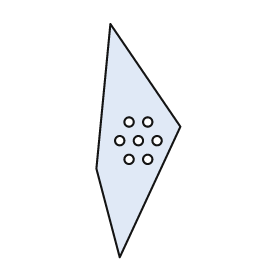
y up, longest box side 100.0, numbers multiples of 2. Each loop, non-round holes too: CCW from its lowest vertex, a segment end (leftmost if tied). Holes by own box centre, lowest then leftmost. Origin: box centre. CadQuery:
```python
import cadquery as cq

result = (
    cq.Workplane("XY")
    .moveTo(-8.0, -50.0)
    .lineTo(18.0, 6.0)
    .lineTo(-12.0, 50.0)
    .lineTo(-18.0, -12.0)
    .close()
    .moveTo(-4.0, -8.0)
    .circle(2.0)
    .moveTo(4.0, -8.0)
    .circle(2.0)
    .moveTo(-8.0, 0.0)
    .circle(2.0)
    .moveTo(0.0, 0.0)
    .circle(2.0)
    .moveTo(8.0, 0.0)
    .circle(2.0)
    .moveTo(-4.0, 8.0)
    .circle(2.0)
    .moveTo(4.0, 8.0)
    .circle(2.0)
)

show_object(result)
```